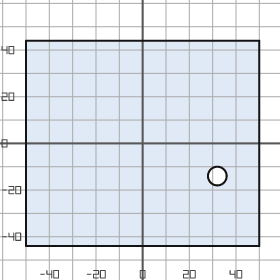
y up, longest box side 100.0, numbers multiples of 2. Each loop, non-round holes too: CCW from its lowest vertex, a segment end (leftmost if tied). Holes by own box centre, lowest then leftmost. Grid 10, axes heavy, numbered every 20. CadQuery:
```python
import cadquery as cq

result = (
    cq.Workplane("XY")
    .moveTo(-50.0, -44.0)
    .lineTo(50.0, -44.0)
    .lineTo(50.0, 44.0)
    .lineTo(-50.0, 44.0)
    .close()
    .moveTo(32.0, -14.0)
    .circle(4.0)
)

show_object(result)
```